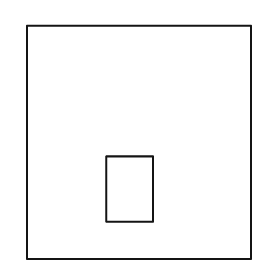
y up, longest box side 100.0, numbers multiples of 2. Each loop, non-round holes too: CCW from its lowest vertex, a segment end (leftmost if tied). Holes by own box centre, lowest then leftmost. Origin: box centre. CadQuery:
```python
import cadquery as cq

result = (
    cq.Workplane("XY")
    .moveTo(-48.0, -50.0)
    .lineTo(48.0, -50.0)
    .lineTo(48.0, 50.0)
    .lineTo(-48.0, 50.0)
    .close()
    .moveTo(-14.0, -34.0)
    .lineTo(6.0, -34.0)
    .lineTo(6.0, -6.0)
    .lineTo(-14.0, -6.0)
    .close()
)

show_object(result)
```